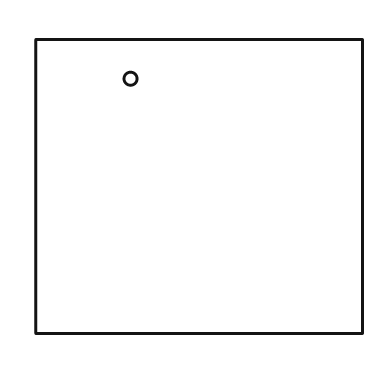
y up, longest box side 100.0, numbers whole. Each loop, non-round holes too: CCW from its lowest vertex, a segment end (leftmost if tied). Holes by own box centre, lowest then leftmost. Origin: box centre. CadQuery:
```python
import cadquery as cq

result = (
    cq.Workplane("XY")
    .moveTo(-50.0, -45.0)
    .lineTo(50.0, -45.0)
    .lineTo(50.0, 45.0)
    .lineTo(-50.0, 45.0)
    .close()
    .moveTo(-21.0, 33.0)
    .circle(2.0)
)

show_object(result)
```